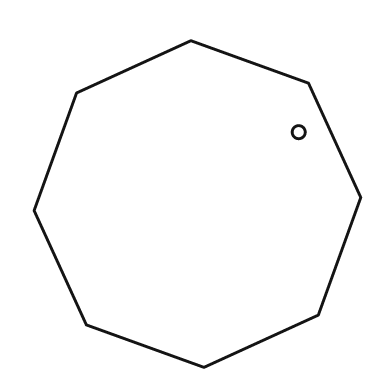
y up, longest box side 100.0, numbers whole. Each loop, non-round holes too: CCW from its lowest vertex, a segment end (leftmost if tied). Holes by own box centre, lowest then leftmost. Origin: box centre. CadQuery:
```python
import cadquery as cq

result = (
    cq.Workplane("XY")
    .moveTo(2.0, -50.0)
    .lineTo(37.0, -34.0)
    .lineTo(50.0, 2.0)
    .lineTo(34.0, 37.0)
    .lineTo(-2.0, 50.0)
    .lineTo(-37.0, 34.0)
    .lineTo(-50.0, -2.0)
    .lineTo(-34.0, -37.0)
    .close()
    .moveTo(31.0, 22.0)
    .circle(2.0)
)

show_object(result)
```